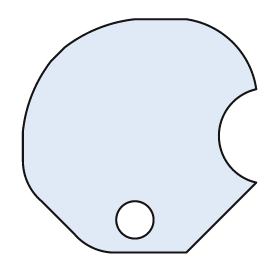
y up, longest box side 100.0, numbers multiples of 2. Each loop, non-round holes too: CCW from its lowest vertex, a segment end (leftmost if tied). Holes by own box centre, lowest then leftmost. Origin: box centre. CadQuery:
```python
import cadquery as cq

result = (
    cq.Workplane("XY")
    .moveTo(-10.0, -50.0)
    .lineTo(20.0, -50.0)
    .lineTo(50.0, -20.0)
    .threePointArc((34.0, 0.0), (50.0, 20.0))
    .threePointArc((40.0, 40.0), (20.0, 50.0))
    .lineTo(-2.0, 50.0)
    .threePointArc((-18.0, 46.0), (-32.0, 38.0))
    .lineTo(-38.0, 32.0)
    .threePointArc((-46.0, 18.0), (-50.0, 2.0))
    .lineTo(-50.0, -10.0)
    .threePointArc((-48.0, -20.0), (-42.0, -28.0))
    .lineTo(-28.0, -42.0)
    .threePointArc((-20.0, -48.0), (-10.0, -50.0))
    .close()
    .moveTo(-2.0, -36.0)
    .circle(8.0)
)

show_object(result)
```